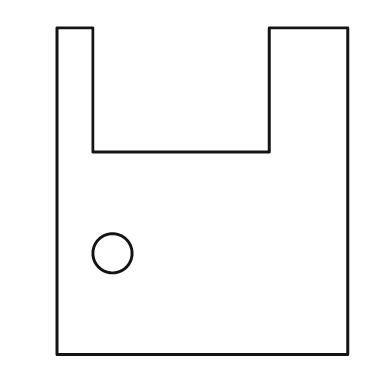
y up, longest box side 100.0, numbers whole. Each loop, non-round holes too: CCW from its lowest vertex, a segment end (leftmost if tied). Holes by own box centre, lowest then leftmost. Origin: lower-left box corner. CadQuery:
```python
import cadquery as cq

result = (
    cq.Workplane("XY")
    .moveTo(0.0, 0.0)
    .lineTo(89.0, 0.0)
    .lineTo(89.0, 100.0)
    .lineTo(65.0, 100.0)
    .lineTo(65.0, 62.0)
    .lineTo(11.0, 62.0)
    .lineTo(11.0, 100.0)
    .lineTo(0.0, 100.0)
    .close()
    .moveTo(17.0, 31.0)
    .circle(6.0)
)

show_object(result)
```